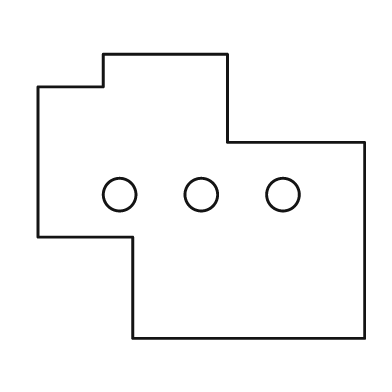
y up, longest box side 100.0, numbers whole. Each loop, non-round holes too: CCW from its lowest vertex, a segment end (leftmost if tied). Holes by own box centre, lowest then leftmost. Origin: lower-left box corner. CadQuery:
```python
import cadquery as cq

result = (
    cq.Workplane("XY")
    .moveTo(29.0, 0.0)
    .lineTo(100.0, 0.0)
    .lineTo(100.0, 60.0)
    .lineTo(58.0, 60.0)
    .lineTo(58.0, 87.0)
    .lineTo(20.0, 87.0)
    .lineTo(20.0, 77.0)
    .lineTo(0.0, 77.0)
    .lineTo(0.0, 31.0)
    .lineTo(29.0, 31.0)
    .close()
    .moveTo(25.0, 44.0)
    .circle(5.0)
    .moveTo(50.0, 44.0)
    .circle(5.0)
    .moveTo(75.0, 44.0)
    .circle(5.0)
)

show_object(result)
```